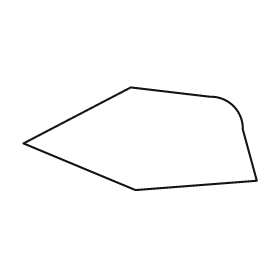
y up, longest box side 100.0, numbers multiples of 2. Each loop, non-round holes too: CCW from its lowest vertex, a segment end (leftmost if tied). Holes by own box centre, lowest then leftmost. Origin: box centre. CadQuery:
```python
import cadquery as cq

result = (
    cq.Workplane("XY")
    .moveTo(-2.0, -22.0)
    .lineTo(50.0, -18.0)
    .lineTo(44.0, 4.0)
    .threePointArc((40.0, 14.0), (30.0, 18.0))
    .lineTo(-4.0, 22.0)
    .lineTo(-50.0, -2.0)
    .close()
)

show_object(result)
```